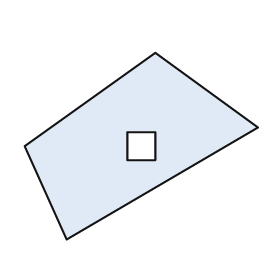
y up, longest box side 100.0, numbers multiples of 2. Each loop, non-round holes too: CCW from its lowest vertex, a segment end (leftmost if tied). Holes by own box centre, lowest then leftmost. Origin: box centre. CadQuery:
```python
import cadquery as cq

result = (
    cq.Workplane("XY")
    .moveTo(-32.0, -40.0)
    .lineTo(50.0, 8.0)
    .lineTo(6.0, 40.0)
    .lineTo(-50.0, 0.0)
    .close()
    .moveTo(-6.0, -6.0)
    .lineTo(6.0, -6.0)
    .lineTo(6.0, 6.0)
    .lineTo(-6.0, 6.0)
    .close()
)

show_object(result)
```